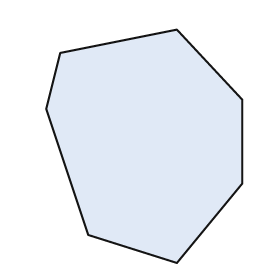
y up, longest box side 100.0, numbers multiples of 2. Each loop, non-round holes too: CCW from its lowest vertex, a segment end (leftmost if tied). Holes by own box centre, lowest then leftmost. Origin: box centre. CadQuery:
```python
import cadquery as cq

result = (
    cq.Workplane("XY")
    .moveTo(14.0, -50.0)
    .lineTo(42.0, -16.0)
    .lineTo(42.0, 20.0)
    .lineTo(14.0, 50.0)
    .lineTo(-36.0, 40.0)
    .lineTo(-42.0, 16.0)
    .lineTo(-24.0, -38.0)
    .close()
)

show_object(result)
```